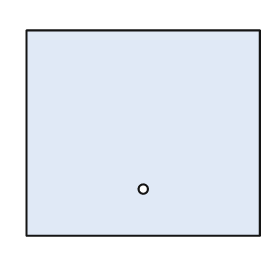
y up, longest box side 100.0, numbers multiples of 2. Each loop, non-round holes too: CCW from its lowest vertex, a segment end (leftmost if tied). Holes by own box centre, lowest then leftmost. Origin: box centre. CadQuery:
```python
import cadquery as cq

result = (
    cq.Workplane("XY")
    .moveTo(-50.0, -44.0)
    .lineTo(50.0, -44.0)
    .lineTo(50.0, 44.0)
    .lineTo(-50.0, 44.0)
    .close()
    .moveTo(0.0, -24.0)
    .circle(2.0)
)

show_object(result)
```